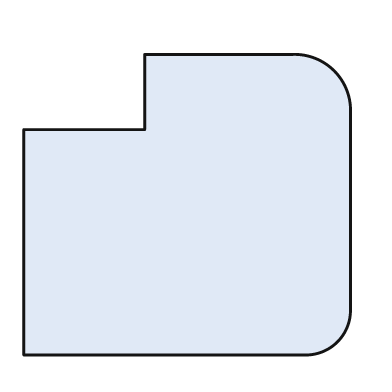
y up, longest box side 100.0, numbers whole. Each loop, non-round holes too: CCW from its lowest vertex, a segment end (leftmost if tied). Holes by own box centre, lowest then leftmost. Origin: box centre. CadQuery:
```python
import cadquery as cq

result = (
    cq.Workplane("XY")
    .moveTo(-50.0, -46.0)
    .lineTo(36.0, -46.0)
    .threePointArc((46.0, -42.0), (50.0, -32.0))
    .lineTo(50.0, 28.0)
    .threePointArc((45.0, 41.0), (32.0, 46.0))
    .lineTo(-13.0, 46.0)
    .lineTo(-13.0, 23.0)
    .lineTo(-50.0, 23.0)
    .close()
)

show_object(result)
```